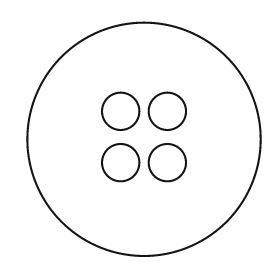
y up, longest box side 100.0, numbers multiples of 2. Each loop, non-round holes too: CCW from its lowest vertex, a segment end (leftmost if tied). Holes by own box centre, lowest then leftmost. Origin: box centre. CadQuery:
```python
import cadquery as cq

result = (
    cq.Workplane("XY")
    .moveTo(0.0, 0.0)
    .circle(50.0)
    .moveTo(-10.0, -10.0)
    .circle(8.0)
    .moveTo(10.0, -10.0)
    .circle(8.0)
    .moveTo(-10.0, 12.0)
    .circle(8.0)
    .moveTo(10.0, 12.0)
    .circle(8.0)
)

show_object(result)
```